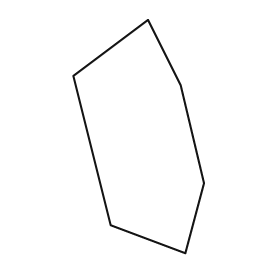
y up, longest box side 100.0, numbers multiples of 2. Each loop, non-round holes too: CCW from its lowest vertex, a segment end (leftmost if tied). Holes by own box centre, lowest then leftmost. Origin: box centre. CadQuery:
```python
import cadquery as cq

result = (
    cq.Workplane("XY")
    .moveTo(20.0, -50.0)
    .lineTo(28.0, -20.0)
    .lineTo(18.0, 22.0)
    .lineTo(4.0, 50.0)
    .lineTo(-28.0, 26.0)
    .lineTo(-12.0, -38.0)
    .close()
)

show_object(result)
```